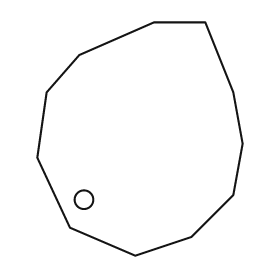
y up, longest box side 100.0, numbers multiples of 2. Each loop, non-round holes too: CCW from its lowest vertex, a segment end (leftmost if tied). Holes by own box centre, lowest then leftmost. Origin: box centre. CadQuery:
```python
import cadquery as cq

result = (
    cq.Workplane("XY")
    .moveTo(-2.0, -50.0)
    .lineTo(22.0, -42.0)
    .lineTo(40.0, -24.0)
    .lineTo(44.0, -2.0)
    .lineTo(40.0, 20.0)
    .lineTo(28.0, 50.0)
    .lineTo(6.0, 50.0)
    .lineTo(-26.0, 36.0)
    .lineTo(-40.0, 20.0)
    .lineTo(-44.0, -8.0)
    .lineTo(-30.0, -38.0)
    .close()
    .moveTo(-24.0, -26.0)
    .circle(4.0)
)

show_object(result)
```